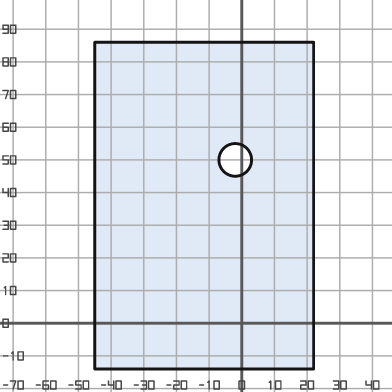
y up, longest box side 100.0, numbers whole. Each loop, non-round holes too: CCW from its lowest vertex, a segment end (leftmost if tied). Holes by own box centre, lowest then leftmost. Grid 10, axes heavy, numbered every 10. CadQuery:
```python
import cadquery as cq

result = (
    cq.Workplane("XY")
    .moveTo(-45.0, -14.0)
    .lineTo(22.0, -14.0)
    .lineTo(22.0, 86.0)
    .lineTo(-45.0, 86.0)
    .close()
    .moveTo(-2.0, 50.0)
    .circle(5.0)
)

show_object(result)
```